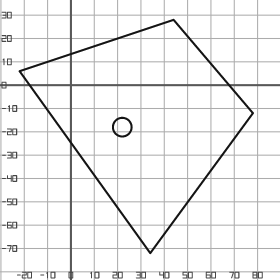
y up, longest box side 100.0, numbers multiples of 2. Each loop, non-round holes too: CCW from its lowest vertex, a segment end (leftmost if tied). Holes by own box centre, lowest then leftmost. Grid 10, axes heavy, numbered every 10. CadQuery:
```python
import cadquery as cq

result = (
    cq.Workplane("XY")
    .moveTo(34.0, -72.0)
    .lineTo(78.0, -12.0)
    .lineTo(44.0, 28.0)
    .lineTo(-22.0, 6.0)
    .close()
    .moveTo(22.0, -18.0)
    .circle(4.0)
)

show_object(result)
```